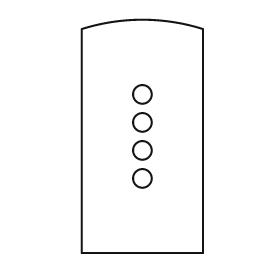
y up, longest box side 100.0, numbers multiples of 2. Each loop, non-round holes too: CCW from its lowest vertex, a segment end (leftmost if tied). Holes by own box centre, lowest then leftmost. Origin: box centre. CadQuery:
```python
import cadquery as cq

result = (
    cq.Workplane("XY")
    .moveTo(-26.0, -50.0)
    .lineTo(26.0, -50.0)
    .lineTo(26.0, 46.0)
    .threePointArc((0.0, 50.0), (-26.0, 46.0))
    .close()
    .moveTo(0.0, -18.0)
    .circle(4.0)
    .moveTo(0.0, -6.0)
    .circle(4.0)
    .moveTo(0.0, 6.0)
    .circle(4.0)
    .moveTo(0.0, 18.0)
    .circle(4.0)
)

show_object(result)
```